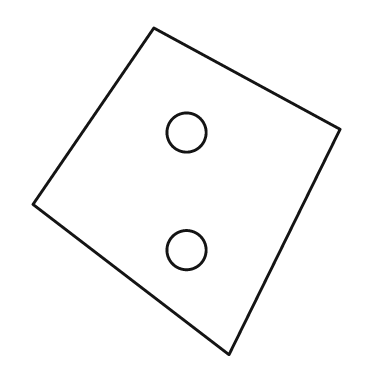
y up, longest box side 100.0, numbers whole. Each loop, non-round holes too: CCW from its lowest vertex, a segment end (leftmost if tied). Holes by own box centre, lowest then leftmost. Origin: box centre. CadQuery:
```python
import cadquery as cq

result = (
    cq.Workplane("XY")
    .moveTo(13.0, -50.0)
    .lineTo(47.0, 19.0)
    .lineTo(-10.0, 50.0)
    .lineTo(-47.0, -4.0)
    .close()
    .moveTo(0.0, -18.0)
    .circle(6.0)
    .moveTo(0.0, 18.0)
    .circle(6.0)
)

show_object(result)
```